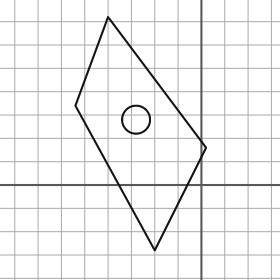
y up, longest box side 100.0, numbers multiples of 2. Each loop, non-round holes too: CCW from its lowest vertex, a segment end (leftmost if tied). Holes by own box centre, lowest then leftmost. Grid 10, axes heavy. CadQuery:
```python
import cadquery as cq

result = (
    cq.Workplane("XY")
    .moveTo(-20.0, -28.0)
    .lineTo(2.0, 16.0)
    .lineTo(-40.0, 72.0)
    .lineTo(-54.0, 34.0)
    .close()
    .moveTo(-28.0, 28.0)
    .circle(6.0)
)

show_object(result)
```